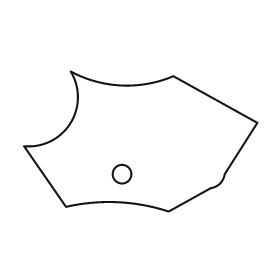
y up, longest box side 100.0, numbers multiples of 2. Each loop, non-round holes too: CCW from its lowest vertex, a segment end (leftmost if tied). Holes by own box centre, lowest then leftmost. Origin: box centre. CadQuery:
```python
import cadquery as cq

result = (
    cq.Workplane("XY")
    .moveTo(12.0, -30.0)
    .lineTo(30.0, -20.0)
    .threePointArc((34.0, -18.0), (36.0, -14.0))
    .lineTo(50.0, 8.0)
    .lineTo(14.0, 28.0)
    .threePointArc((-8.0, 24.0), (-30.0, 30.0))
    .threePointArc((-30.0, 8.0), (-50.0, -2.0))
    .lineTo(-32.0, -28.0)
    .threePointArc((-10.0, -26.0), (12.0, -30.0))
    .close()
    .moveTo(-8.0, -14.0)
    .circle(4.0)
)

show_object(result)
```